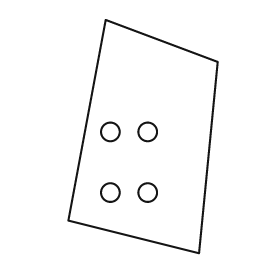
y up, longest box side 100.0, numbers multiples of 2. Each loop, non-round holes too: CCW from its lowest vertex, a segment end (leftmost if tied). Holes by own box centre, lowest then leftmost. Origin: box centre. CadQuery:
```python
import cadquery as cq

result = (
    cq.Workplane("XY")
    .moveTo(24.0, -50.0)
    .lineTo(32.0, 32.0)
    .lineTo(-16.0, 50.0)
    .lineTo(-32.0, -36.0)
    .close()
    .moveTo(-14.0, -24.0)
    .circle(4.0)
    .moveTo(2.0, -24.0)
    .circle(4.0)
    .moveTo(-14.0, 2.0)
    .circle(4.0)
    .moveTo(2.0, 2.0)
    .circle(4.0)
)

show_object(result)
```